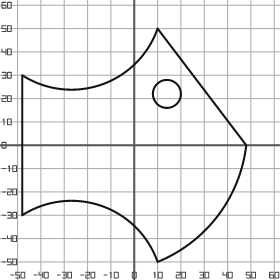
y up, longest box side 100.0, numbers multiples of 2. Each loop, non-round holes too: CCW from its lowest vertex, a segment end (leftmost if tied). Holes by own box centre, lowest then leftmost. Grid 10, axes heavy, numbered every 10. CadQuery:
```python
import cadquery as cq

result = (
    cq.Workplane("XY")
    .moveTo(10.0, -50.0)
    .threePointArc((36.0, -30.0), (48.0, 0.0))
    .lineTo(10.0, 50.0)
    .threePointArc((-14.0, 26.0), (-48.0, 30.0))
    .lineTo(-48.0, -30.0)
    .threePointArc((-14.0, -26.0), (10.0, -50.0))
    .close()
    .moveTo(14.0, 22.0)
    .circle(6.0)
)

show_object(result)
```